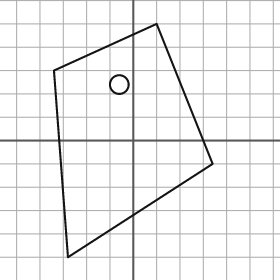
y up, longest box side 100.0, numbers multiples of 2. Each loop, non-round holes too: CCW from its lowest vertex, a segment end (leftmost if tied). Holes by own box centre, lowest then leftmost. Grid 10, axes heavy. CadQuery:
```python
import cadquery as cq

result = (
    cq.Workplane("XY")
    .moveTo(-28.0, -50.0)
    .lineTo(34.0, -10.0)
    .lineTo(10.0, 50.0)
    .lineTo(-34.0, 30.0)
    .close()
    .moveTo(-6.0, 24.0)
    .circle(4.0)
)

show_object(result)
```